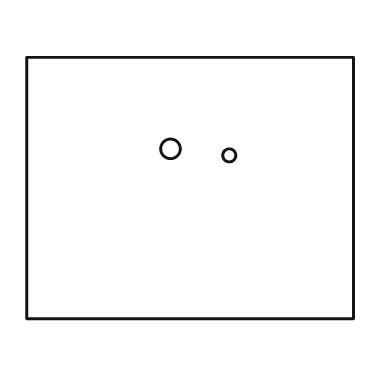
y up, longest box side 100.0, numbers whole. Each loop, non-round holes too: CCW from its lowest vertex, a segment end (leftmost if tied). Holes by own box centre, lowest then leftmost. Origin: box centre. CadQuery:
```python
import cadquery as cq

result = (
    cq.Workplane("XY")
    .moveTo(-50.0, -40.0)
    .lineTo(50.0, -40.0)
    .lineTo(50.0, 40.0)
    .lineTo(-50.0, 40.0)
    .close()
    .moveTo(12.0, 10.0)
    .circle(2.0)
    .moveTo(-6.0, 12.0)
    .circle(3.0)
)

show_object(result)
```